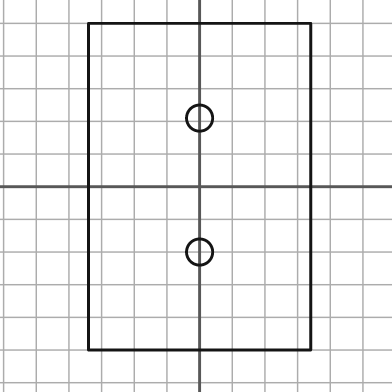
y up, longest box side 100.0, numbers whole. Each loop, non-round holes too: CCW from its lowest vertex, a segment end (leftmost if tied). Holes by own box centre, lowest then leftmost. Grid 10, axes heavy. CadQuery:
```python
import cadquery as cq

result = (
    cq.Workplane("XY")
    .moveTo(-34.0, -50.0)
    .lineTo(34.0, -50.0)
    .lineTo(34.0, 50.0)
    .lineTo(-34.0, 50.0)
    .close()
    .moveTo(0.0, -20.0)
    .circle(4.0)
    .moveTo(0.0, 21.0)
    .circle(4.0)
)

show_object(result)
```